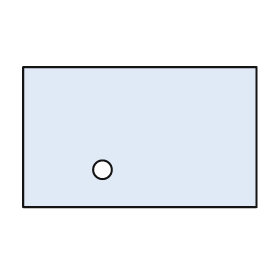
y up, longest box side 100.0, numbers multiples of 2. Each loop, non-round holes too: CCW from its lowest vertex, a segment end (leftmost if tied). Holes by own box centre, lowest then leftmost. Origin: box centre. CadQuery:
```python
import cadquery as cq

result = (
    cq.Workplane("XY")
    .moveTo(-50.0, -30.0)
    .lineTo(50.0, -30.0)
    .lineTo(50.0, 30.0)
    .lineTo(-50.0, 30.0)
    .close()
    .moveTo(-16.0, -14.0)
    .circle(4.0)
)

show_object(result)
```